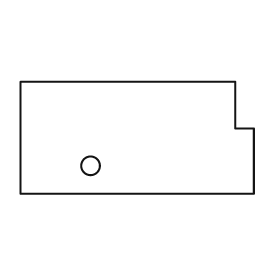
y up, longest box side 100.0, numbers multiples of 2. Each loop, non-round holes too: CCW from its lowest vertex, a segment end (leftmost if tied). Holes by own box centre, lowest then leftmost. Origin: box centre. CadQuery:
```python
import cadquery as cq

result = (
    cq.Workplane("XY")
    .moveTo(-50.0, -24.0)
    .lineTo(50.0, -24.0)
    .lineTo(50.0, 4.0)
    .lineTo(42.0, 4.0)
    .lineTo(42.0, 24.0)
    .lineTo(-50.0, 24.0)
    .close()
    .moveTo(-20.0, -12.0)
    .circle(4.0)
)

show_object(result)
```